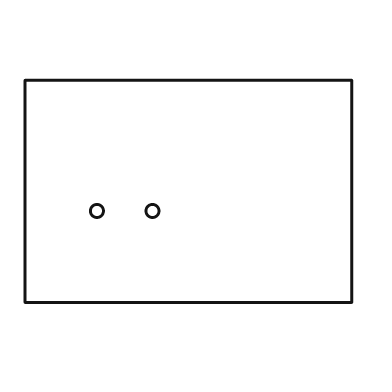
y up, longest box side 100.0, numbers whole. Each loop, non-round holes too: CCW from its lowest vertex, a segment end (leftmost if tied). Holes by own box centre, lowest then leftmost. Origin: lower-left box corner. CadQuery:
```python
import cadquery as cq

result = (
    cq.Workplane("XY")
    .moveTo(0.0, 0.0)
    .lineTo(100.0, 0.0)
    .lineTo(100.0, 68.0)
    .lineTo(0.0, 68.0)
    .close()
    .moveTo(22.0, 28.0)
    .circle(2.0)
    .moveTo(39.0, 28.0)
    .circle(2.0)
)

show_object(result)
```